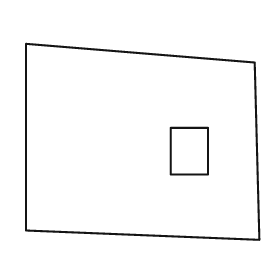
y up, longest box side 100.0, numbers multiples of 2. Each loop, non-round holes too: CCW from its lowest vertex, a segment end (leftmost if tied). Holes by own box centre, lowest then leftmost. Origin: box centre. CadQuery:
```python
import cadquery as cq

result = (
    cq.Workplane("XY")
    .moveTo(50.0, -42.0)
    .lineTo(48.0, 34.0)
    .lineTo(-50.0, 42.0)
    .lineTo(-50.0, -38.0)
    .close()
    .moveTo(12.0, -14.0)
    .lineTo(28.0, -14.0)
    .lineTo(28.0, 6.0)
    .lineTo(12.0, 6.0)
    .close()
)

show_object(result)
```